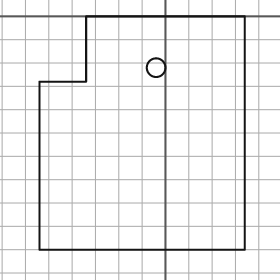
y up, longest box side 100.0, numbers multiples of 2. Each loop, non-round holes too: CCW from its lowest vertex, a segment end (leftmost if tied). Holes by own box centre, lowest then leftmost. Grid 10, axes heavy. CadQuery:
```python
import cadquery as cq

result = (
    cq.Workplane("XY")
    .moveTo(-54.0, -100.0)
    .lineTo(34.0, -100.0)
    .lineTo(34.0, 0.0)
    .lineTo(-34.0, 0.0)
    .lineTo(-34.0, -28.0)
    .lineTo(-54.0, -28.0)
    .close()
    .moveTo(-4.0, -22.0)
    .circle(4.0)
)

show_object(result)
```